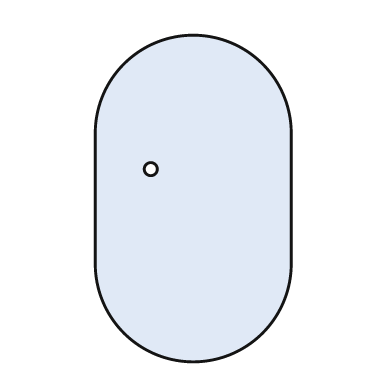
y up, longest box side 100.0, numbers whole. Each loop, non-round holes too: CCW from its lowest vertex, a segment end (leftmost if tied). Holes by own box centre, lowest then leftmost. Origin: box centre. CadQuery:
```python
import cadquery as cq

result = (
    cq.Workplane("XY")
    .moveTo(-30.0, -20.0)
    .threePointArc((0.0, -50.0), (30.0, -20.0))
    .lineTo(30.0, 20.0)
    .threePointArc((0.0, 50.0), (-30.0, 20.0))
    .close()
    .moveTo(-13.0, 9.0)
    .circle(2.0)
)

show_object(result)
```